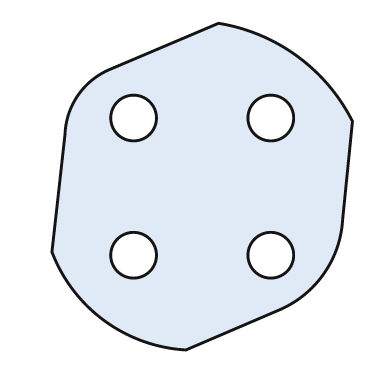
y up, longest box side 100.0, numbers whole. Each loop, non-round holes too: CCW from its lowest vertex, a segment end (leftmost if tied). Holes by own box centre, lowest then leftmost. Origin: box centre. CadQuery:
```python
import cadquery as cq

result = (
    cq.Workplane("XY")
    .moveTo(-5.0, -50.0)
    .lineTo(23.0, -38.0)
    .threePointArc((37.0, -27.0), (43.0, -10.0))
    .lineTo(46.0, 20.0)
    .threePointArc((29.0, 40.0), (5.0, 50.0))
    .lineTo(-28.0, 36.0)
    .threePointArc((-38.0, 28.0), (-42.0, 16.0))
    .lineTo(-46.0, -20.0)
    .threePointArc((-30.0, -41.0), (-5.0, -50.0))
    .close()
    .moveTo(-21.0, -21.0)
    .circle(7.0)
    .moveTo(21.0, -21.0)
    .circle(7.0)
    .moveTo(-21.0, 21.0)
    .circle(7.0)
    .moveTo(21.0, 21.0)
    .circle(7.0)
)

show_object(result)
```